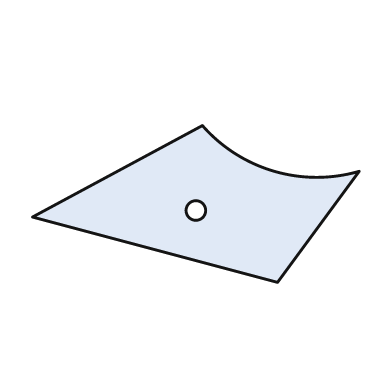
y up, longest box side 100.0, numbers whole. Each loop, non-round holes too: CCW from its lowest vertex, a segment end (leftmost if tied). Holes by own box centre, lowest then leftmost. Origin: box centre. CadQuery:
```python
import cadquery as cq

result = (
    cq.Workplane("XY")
    .moveTo(25.0, -24.0)
    .lineTo(50.0, 10.0)
    .threePointArc((24.0, 10.0), (2.0, 24.0))
    .lineTo(-50.0, -4.0)
    .close()
    .moveTo(0.0, -2.0)
    .circle(3.0)
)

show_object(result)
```